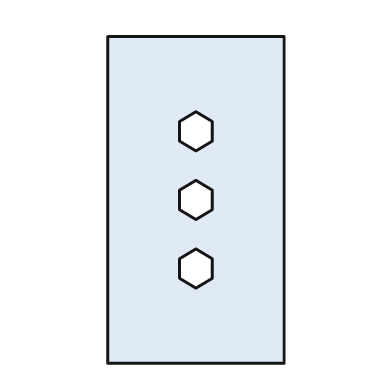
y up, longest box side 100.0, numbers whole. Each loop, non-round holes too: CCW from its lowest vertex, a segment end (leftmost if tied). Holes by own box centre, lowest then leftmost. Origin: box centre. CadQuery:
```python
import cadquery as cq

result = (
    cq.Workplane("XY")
    .moveTo(-27.0, -50.0)
    .lineTo(27.0, -50.0)
    .lineTo(27.0, 50.0)
    .lineTo(-27.0, 50.0)
    .close()
    .moveTo(0.0, -27.0)
    .lineTo(5.0, -24.0)
    .lineTo(5.0, -18.0)
    .lineTo(0.0, -15.0)
    .lineTo(-5.0, -18.0)
    .lineTo(-5.0, -24.0)
    .close()
    .moveTo(0.0, -6.0)
    .lineTo(5.0, -3.0)
    .lineTo(5.0, 3.0)
    .lineTo(0.0, 6.0)
    .lineTo(-5.0, 3.0)
    .lineTo(-5.0, -3.0)
    .close()
    .moveTo(0.0, 15.0)
    .lineTo(5.0, 18.0)
    .lineTo(5.0, 24.0)
    .lineTo(0.0, 27.0)
    .lineTo(-5.0, 24.0)
    .lineTo(-5.0, 18.0)
    .close()
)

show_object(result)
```